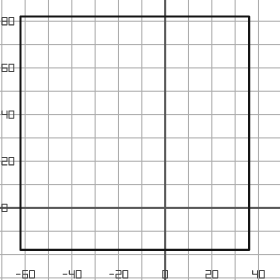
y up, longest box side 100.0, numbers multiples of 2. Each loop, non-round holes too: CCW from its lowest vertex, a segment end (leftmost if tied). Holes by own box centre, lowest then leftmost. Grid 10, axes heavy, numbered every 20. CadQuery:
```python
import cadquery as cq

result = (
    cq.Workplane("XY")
    .moveTo(-62.0, -18.0)
    .lineTo(36.0, -18.0)
    .lineTo(36.0, 82.0)
    .lineTo(-62.0, 82.0)
    .close()
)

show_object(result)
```